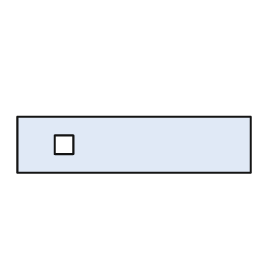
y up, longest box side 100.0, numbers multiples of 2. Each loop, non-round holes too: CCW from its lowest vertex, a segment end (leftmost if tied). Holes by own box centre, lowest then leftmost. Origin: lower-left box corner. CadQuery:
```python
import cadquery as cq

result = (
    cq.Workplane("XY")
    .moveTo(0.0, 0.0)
    .lineTo(100.0, 0.0)
    .lineTo(100.0, 24.0)
    .lineTo(0.0, 24.0)
    .close()
    .moveTo(16.0, 8.0)
    .lineTo(24.0, 8.0)
    .lineTo(24.0, 16.0)
    .lineTo(16.0, 16.0)
    .close()
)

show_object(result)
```